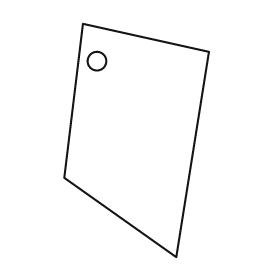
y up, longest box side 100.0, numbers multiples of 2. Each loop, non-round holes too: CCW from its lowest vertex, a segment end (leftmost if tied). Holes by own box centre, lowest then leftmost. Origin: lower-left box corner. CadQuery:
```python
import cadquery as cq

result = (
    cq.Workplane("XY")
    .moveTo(48.0, 0.0)
    .lineTo(62.0, 88.0)
    .lineTo(8.0, 100.0)
    .lineTo(0.0, 34.0)
    .close()
    .moveTo(14.0, 84.0)
    .circle(4.0)
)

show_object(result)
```